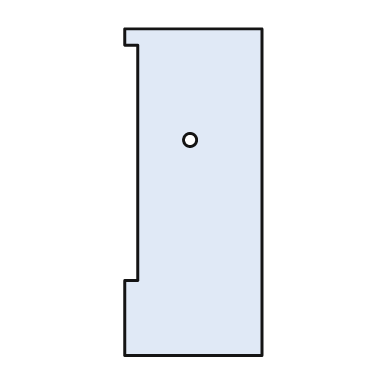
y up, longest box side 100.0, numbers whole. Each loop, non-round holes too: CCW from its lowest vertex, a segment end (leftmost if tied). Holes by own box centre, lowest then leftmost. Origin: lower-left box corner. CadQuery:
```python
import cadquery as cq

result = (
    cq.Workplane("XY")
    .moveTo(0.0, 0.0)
    .lineTo(42.0, 0.0)
    .lineTo(42.0, 100.0)
    .lineTo(0.0, 100.0)
    .lineTo(0.0, 95.0)
    .lineTo(4.0, 95.0)
    .lineTo(4.0, 23.0)
    .lineTo(0.0, 23.0)
    .close()
    .moveTo(20.0, 66.0)
    .circle(2.0)
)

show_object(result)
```